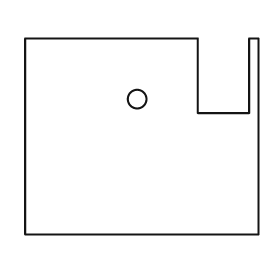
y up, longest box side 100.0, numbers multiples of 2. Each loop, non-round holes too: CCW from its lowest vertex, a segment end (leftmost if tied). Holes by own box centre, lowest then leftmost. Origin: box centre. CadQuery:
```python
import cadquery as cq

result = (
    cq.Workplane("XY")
    .moveTo(-50.0, -42.0)
    .lineTo(50.0, -42.0)
    .lineTo(50.0, 42.0)
    .lineTo(46.0, 42.0)
    .lineTo(46.0, 10.0)
    .lineTo(24.0, 10.0)
    .lineTo(24.0, 42.0)
    .lineTo(-50.0, 42.0)
    .close()
    .moveTo(-2.0, 16.0)
    .circle(4.0)
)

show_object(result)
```